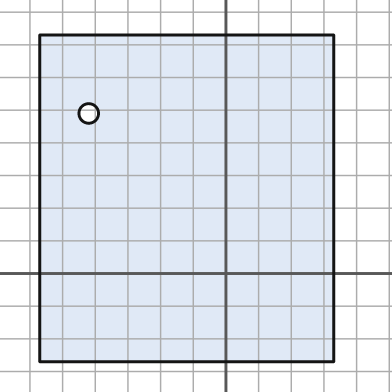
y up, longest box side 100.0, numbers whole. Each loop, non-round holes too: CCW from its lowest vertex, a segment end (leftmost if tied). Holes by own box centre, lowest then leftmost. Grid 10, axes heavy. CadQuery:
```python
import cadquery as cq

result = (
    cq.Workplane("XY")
    .moveTo(-57.0, -27.0)
    .lineTo(33.0, -27.0)
    .lineTo(33.0, 73.0)
    .lineTo(-57.0, 73.0)
    .close()
    .moveTo(-42.0, 49.0)
    .circle(3.0)
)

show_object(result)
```